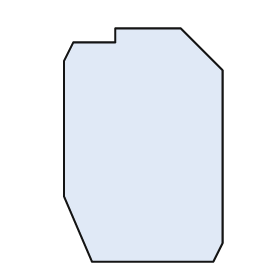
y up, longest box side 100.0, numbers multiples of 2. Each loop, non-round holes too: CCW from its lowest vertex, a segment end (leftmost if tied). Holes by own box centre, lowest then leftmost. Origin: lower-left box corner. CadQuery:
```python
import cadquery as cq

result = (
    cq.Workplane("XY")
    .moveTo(12.0, 0.0)
    .lineTo(64.0, 0.0)
    .lineTo(68.0, 8.0)
    .lineTo(68.0, 82.0)
    .lineTo(50.0, 100.0)
    .lineTo(22.0, 100.0)
    .lineTo(22.0, 94.0)
    .lineTo(4.0, 94.0)
    .lineTo(0.0, 86.0)
    .lineTo(0.0, 28.0)
    .close()
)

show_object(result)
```